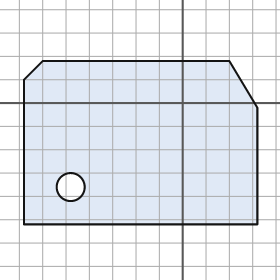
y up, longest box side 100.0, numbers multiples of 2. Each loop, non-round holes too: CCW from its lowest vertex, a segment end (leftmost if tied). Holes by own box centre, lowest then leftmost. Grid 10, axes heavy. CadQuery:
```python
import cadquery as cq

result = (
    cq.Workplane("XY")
    .moveTo(-68.0, -52.0)
    .lineTo(32.0, -52.0)
    .lineTo(32.0, -2.0)
    .lineTo(20.0, 18.0)
    .lineTo(-60.0, 18.0)
    .lineTo(-68.0, 10.0)
    .close()
    .moveTo(-48.0, -36.0)
    .circle(6.0)
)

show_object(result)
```